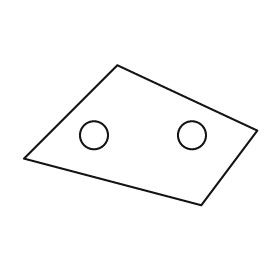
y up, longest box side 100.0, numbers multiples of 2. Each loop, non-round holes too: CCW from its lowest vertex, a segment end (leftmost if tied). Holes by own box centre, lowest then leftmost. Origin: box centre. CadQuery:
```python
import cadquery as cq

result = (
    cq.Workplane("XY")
    .moveTo(26.0, -30.0)
    .lineTo(50.0, 2.0)
    .lineTo(-10.0, 30.0)
    .lineTo(-50.0, -10.0)
    .close()
    .moveTo(-20.0, 0.0)
    .circle(6.0)
    .moveTo(22.0, 0.0)
    .circle(6.0)
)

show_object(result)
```